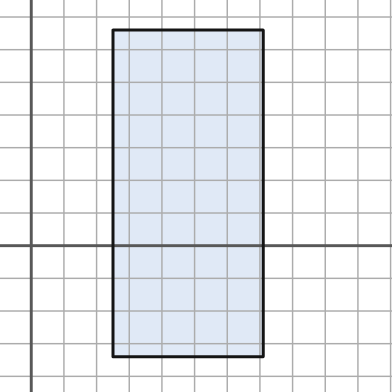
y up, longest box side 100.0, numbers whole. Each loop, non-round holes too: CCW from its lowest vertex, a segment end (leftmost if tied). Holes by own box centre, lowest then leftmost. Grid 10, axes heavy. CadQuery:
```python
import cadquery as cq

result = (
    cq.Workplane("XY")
    .moveTo(25.0, -34.0)
    .lineTo(71.0, -34.0)
    .lineTo(71.0, 66.0)
    .lineTo(25.0, 66.0)
    .close()
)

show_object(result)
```